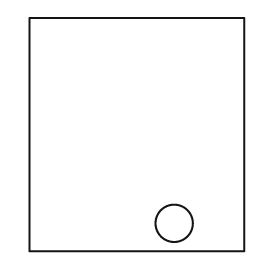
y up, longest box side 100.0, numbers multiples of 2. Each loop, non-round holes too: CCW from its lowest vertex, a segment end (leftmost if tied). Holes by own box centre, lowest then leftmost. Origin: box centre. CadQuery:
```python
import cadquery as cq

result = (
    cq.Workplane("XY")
    .moveTo(-46.0, -50.0)
    .lineTo(46.0, -50.0)
    .lineTo(46.0, 50.0)
    .lineTo(-46.0, 50.0)
    .close()
    .moveTo(16.0, -38.0)
    .circle(8.0)
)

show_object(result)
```